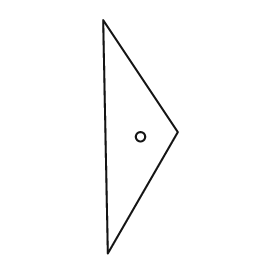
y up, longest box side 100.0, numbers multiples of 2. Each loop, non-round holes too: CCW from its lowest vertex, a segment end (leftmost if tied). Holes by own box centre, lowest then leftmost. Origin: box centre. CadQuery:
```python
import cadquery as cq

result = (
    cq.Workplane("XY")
    .moveTo(-14.0, -50.0)
    .lineTo(16.0, 2.0)
    .lineTo(-16.0, 50.0)
    .close()
    .moveTo(0.0, 0.0)
    .circle(2.0)
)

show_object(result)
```